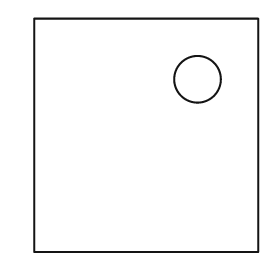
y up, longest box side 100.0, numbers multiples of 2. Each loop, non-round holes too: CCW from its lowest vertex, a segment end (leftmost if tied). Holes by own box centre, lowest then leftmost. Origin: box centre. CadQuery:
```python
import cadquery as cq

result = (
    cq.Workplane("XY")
    .moveTo(-48.0, -50.0)
    .lineTo(48.0, -50.0)
    .lineTo(48.0, 50.0)
    .lineTo(-48.0, 50.0)
    .close()
    .moveTo(22.0, 24.0)
    .circle(10.0)
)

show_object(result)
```